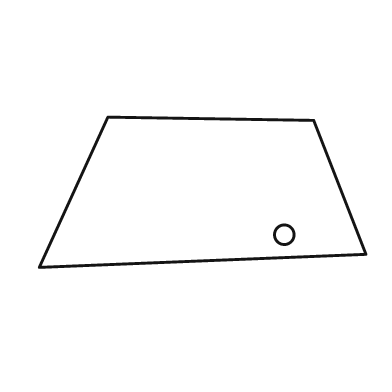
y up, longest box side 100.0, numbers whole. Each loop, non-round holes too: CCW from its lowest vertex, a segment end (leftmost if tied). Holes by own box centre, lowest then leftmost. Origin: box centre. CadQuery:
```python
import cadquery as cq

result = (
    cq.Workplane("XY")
    .moveTo(-50.0, -23.0)
    .lineTo(50.0, -19.0)
    .lineTo(34.0, 22.0)
    .lineTo(-29.0, 23.0)
    .close()
    .moveTo(25.0, -13.0)
    .circle(3.0)
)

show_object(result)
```